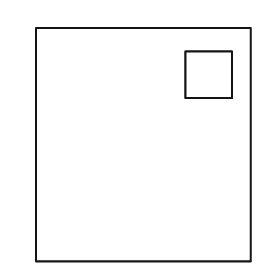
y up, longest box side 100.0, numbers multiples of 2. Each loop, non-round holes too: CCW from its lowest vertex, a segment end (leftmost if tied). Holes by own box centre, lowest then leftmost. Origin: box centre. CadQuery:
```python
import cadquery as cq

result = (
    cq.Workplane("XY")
    .moveTo(-46.0, -50.0)
    .lineTo(46.0, -50.0)
    .lineTo(46.0, 50.0)
    .lineTo(-46.0, 50.0)
    .close()
    .moveTo(18.0, 20.0)
    .lineTo(38.0, 20.0)
    .lineTo(38.0, 40.0)
    .lineTo(18.0, 40.0)
    .close()
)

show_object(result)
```